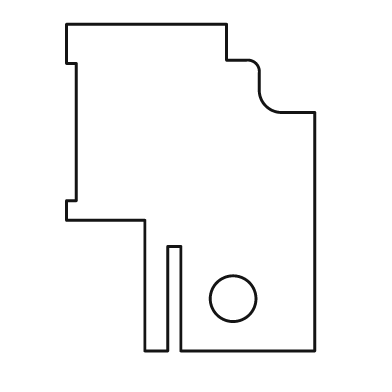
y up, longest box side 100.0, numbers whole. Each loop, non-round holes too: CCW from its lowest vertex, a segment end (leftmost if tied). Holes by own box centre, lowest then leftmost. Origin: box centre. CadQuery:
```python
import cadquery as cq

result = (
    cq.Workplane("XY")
    .moveTo(-14.0, -50.0)
    .lineTo(-7.0, -50.0)
    .lineTo(-7.0, -18.0)
    .lineTo(-3.0, -18.0)
    .lineTo(-3.0, -50.0)
    .lineTo(38.0, -50.0)
    .lineTo(38.0, 23.0)
    .lineTo(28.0, 23.0)
    .threePointArc((23.0, 25.0), (21.0, 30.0))
    .lineTo(21.0, 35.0)
    .threePointArc((20.0, 38.0), (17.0, 39.0))
    .lineTo(11.0, 39.0)
    .lineTo(11.0, 50.0)
    .lineTo(-38.0, 50.0)
    .lineTo(-38.0, 38.0)
    .lineTo(-35.0, 38.0)
    .lineTo(-35.0, -4.0)
    .lineTo(-38.0, -4.0)
    .lineTo(-38.0, -10.0)
    .lineTo(-14.0, -10.0)
    .close()
    .moveTo(13.0, -34.0)
    .circle(7.0)
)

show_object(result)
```